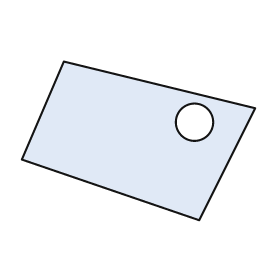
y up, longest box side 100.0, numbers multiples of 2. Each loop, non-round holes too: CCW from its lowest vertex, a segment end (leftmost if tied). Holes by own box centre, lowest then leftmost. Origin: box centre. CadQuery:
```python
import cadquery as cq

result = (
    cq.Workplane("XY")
    .moveTo(26.0, -34.0)
    .lineTo(50.0, 14.0)
    .lineTo(-32.0, 34.0)
    .lineTo(-50.0, -8.0)
    .close()
    .moveTo(24.0, 8.0)
    .circle(8.0)
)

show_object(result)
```